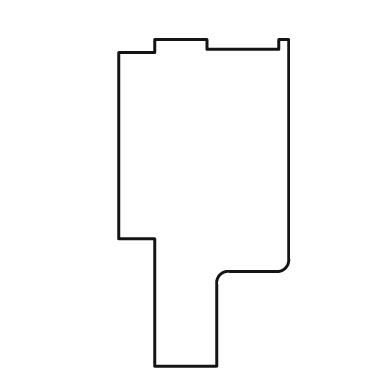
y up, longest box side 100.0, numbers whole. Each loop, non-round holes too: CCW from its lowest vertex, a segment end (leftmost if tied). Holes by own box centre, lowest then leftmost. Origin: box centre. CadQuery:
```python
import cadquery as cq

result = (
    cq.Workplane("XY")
    .moveTo(-15.0, -50.0)
    .lineTo(4.0, -50.0)
    .lineTo(4.0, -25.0)
    .threePointArc((5.0, -22.0), (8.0, -21.0))
    .lineTo(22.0, -21.0)
    .threePointArc((25.0, -20.0), (26.0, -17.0))
    .lineTo(26.0, 50.0)
    .lineTo(23.0, 50.0)
    .lineTo(23.0, 47.0)
    .lineTo(1.0, 47.0)
    .lineTo(1.0, 50.0)
    .lineTo(-15.0, 50.0)
    .lineTo(-15.0, 46.0)
    .lineTo(-26.0, 46.0)
    .lineTo(-26.0, -11.0)
    .lineTo(-15.0, -11.0)
    .close()
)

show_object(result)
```